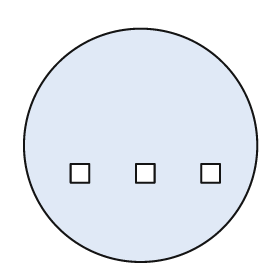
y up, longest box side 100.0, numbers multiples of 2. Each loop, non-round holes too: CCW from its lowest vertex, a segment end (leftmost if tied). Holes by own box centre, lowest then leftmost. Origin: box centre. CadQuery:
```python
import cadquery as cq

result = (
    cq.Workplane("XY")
    .moveTo(0.0, 0.0)
    .circle(50.0)
    .moveTo(-30.0, -16.0)
    .lineTo(-22.0, -16.0)
    .lineTo(-22.0, -8.0)
    .lineTo(-30.0, -8.0)
    .close()
    .moveTo(-2.0, -16.0)
    .lineTo(6.0, -16.0)
    .lineTo(6.0, -8.0)
    .lineTo(-2.0, -8.0)
    .close()
    .moveTo(26.0, -16.0)
    .lineTo(34.0, -16.0)
    .lineTo(34.0, -8.0)
    .lineTo(26.0, -8.0)
    .close()
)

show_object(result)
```